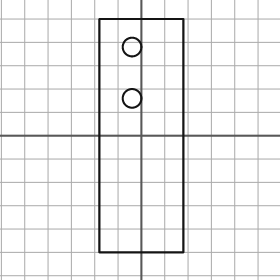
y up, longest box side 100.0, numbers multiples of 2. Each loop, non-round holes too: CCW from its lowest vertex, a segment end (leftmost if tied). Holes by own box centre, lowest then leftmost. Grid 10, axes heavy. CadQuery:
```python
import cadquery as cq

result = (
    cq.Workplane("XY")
    .moveTo(-18.0, -50.0)
    .lineTo(18.0, -50.0)
    .lineTo(18.0, 50.0)
    .lineTo(-18.0, 50.0)
    .close()
    .moveTo(-4.0, 16.0)
    .circle(4.0)
    .moveTo(-4.0, 38.0)
    .circle(4.0)
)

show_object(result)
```